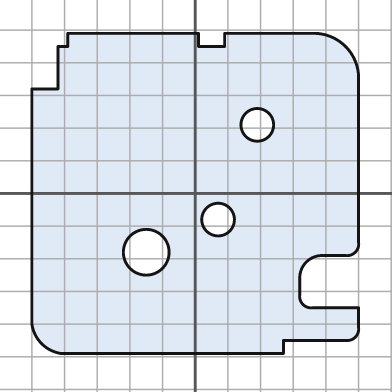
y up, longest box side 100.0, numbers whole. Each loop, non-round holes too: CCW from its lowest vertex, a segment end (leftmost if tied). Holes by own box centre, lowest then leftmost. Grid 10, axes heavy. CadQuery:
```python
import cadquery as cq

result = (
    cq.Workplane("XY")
    .moveTo(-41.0, -49.0)
    .lineTo(27.0, -49.0)
    .lineTo(27.0, -45.0)
    .lineTo(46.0, -45.0)
    .threePointArc((49.0, -44.0), (50.0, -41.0))
    .lineTo(50.0, -35.0)
    .lineTo(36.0, -35.0)
    .threePointArc((33.0, -34.0), (32.0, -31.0))
    .lineTo(32.0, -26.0)
    .threePointArc((34.0, -21.0), (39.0, -19.0))
    .lineTo(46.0, -19.0)
    .threePointArc((49.0, -18.0), (50.0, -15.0))
    .lineTo(50.0, 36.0)
    .threePointArc((46.0, 45.0), (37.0, 49.0))
    .lineTo(9.0, 49.0)
    .lineTo(9.0, 45.0)
    .lineTo(1.0, 45.0)
    .lineTo(1.0, 49.0)
    .lineTo(-39.0, 49.0)
    .lineTo(-39.0, 45.0)
    .lineTo(-42.0, 45.0)
    .lineTo(-42.0, 32.0)
    .lineTo(-50.0, 32.0)
    .lineTo(-50.0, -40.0)
    .threePointArc((-47.0, -46.0), (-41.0, -49.0))
    .close()
    .moveTo(-15.0, -18.0)
    .circle(7.0)
    .moveTo(7.0, -8.0)
    .circle(5.0)
    .moveTo(19.0, 21.0)
    .circle(5.0)
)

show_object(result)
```